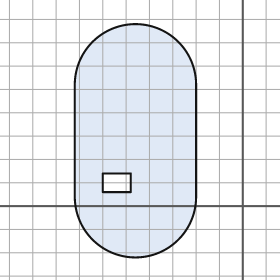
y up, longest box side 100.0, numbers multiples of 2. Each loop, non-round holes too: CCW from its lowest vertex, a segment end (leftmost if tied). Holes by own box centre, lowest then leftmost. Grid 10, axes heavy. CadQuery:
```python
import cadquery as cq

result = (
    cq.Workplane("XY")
    .moveTo(-72.0, 4.0)
    .threePointArc((-46.0, -22.0), (-20.0, 4.0))
    .lineTo(-20.0, 52.0)
    .threePointArc((-46.0, 78.0), (-72.0, 52.0))
    .close()
    .moveTo(-60.0, 6.0)
    .lineTo(-48.0, 6.0)
    .lineTo(-48.0, 14.0)
    .lineTo(-60.0, 14.0)
    .close()
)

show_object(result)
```